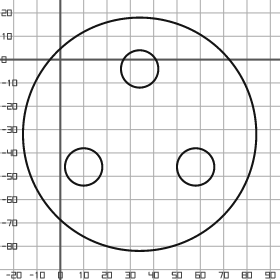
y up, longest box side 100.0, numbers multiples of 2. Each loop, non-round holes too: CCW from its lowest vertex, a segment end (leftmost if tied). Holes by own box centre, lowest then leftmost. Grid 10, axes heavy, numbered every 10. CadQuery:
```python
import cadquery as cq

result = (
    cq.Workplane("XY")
    .moveTo(34.0, -32.0)
    .circle(50.0)
    .moveTo(10.0, -46.0)
    .circle(8.0)
    .moveTo(58.0, -46.0)
    .circle(8.0)
    .moveTo(34.0, -4.0)
    .circle(8.0)
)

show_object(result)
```